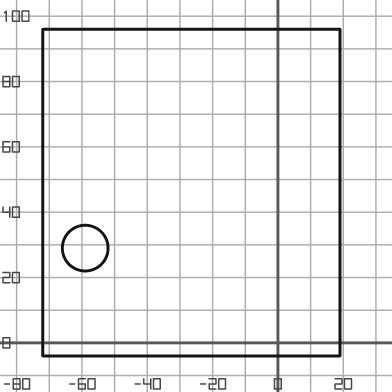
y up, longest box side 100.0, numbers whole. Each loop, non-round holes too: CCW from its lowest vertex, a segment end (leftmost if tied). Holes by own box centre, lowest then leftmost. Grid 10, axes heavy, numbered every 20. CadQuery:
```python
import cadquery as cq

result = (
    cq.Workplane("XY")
    .moveTo(-72.0, -4.0)
    .lineTo(19.0, -4.0)
    .lineTo(19.0, 96.0)
    .lineTo(-72.0, 96.0)
    .close()
    .moveTo(-59.0, 29.0)
    .circle(7.0)
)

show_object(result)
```